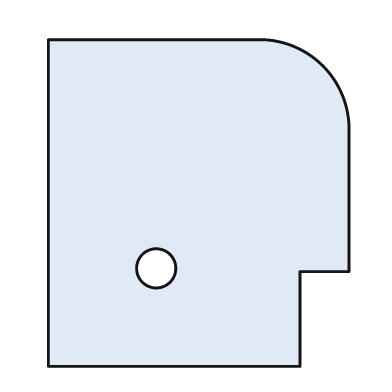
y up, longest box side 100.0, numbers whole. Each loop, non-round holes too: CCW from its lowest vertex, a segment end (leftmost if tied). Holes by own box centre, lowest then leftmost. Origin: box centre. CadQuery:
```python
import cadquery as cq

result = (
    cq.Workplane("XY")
    .moveTo(-46.0, -50.0)
    .lineTo(31.0, -50.0)
    .lineTo(31.0, -21.0)
    .lineTo(46.0, -21.0)
    .lineTo(46.0, 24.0)
    .threePointArc((38.0, 42.0), (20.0, 50.0))
    .lineTo(-46.0, 50.0)
    .close()
    .moveTo(-13.0, -20.0)
    .circle(6.0)
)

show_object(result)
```